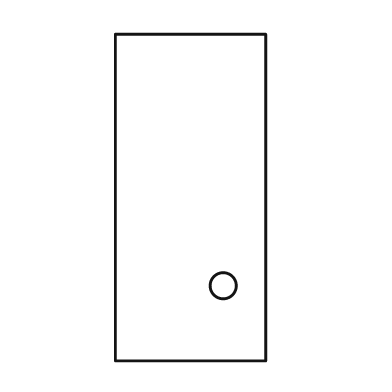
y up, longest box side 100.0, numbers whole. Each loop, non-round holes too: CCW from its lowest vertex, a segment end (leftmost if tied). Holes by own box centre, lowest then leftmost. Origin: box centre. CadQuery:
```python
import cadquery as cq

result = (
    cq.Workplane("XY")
    .moveTo(-23.0, -50.0)
    .lineTo(23.0, -50.0)
    .lineTo(23.0, 50.0)
    .lineTo(-23.0, 50.0)
    .close()
    .moveTo(10.0, -27.0)
    .circle(4.0)
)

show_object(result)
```